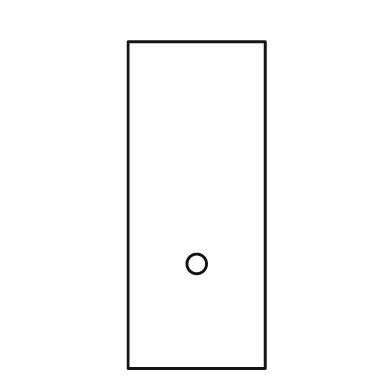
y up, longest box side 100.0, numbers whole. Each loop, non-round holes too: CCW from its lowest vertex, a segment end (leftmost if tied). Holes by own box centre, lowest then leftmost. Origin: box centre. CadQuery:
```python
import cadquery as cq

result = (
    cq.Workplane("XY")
    .moveTo(-21.0, -50.0)
    .lineTo(21.0, -50.0)
    .lineTo(21.0, 50.0)
    .lineTo(-21.0, 50.0)
    .close()
    .moveTo(0.0, -18.0)
    .circle(3.0)
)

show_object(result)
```